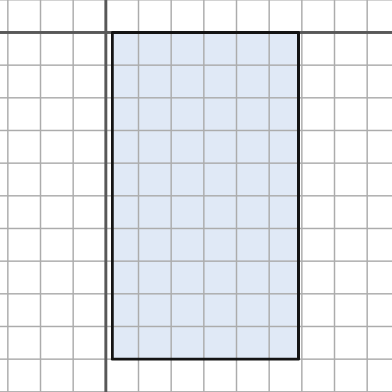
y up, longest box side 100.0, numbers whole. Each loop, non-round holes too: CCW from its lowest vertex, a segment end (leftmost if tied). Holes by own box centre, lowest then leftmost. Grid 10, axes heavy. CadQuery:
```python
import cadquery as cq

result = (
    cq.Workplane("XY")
    .moveTo(2.0, -100.0)
    .lineTo(59.0, -100.0)
    .lineTo(59.0, 0.0)
    .lineTo(2.0, 0.0)
    .close()
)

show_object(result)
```